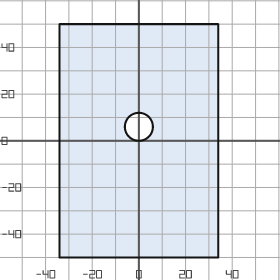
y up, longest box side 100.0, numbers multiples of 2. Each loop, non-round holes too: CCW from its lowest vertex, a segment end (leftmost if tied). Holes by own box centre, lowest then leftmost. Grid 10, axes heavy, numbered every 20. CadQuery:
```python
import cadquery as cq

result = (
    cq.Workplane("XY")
    .moveTo(-34.0, -50.0)
    .lineTo(34.0, -50.0)
    .lineTo(34.0, 50.0)
    .lineTo(-34.0, 50.0)
    .close()
    .moveTo(0.0, 6.0)
    .circle(6.0)
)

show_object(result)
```